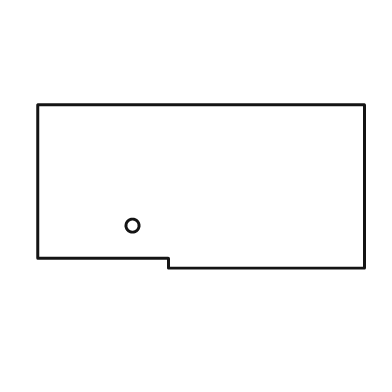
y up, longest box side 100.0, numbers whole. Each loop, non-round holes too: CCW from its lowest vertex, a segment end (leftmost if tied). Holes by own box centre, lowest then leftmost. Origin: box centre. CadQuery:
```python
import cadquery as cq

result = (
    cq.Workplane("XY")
    .moveTo(-10.0, -25.0)
    .lineTo(50.0, -25.0)
    .lineTo(50.0, 25.0)
    .lineTo(-50.0, 25.0)
    .lineTo(-50.0, -22.0)
    .lineTo(-10.0, -22.0)
    .close()
    .moveTo(-21.0, -12.0)
    .circle(2.0)
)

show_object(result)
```